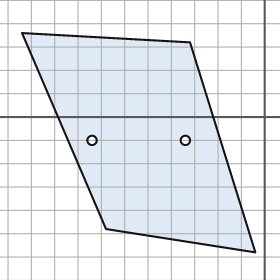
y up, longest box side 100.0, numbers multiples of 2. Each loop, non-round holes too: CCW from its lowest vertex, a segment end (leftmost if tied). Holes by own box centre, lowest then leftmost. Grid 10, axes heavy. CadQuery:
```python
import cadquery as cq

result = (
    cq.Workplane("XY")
    .moveTo(-4.0, -58.0)
    .lineTo(-32.0, 32.0)
    .lineTo(-104.0, 36.0)
    .lineTo(-68.0, -48.0)
    .close()
    .moveTo(-74.0, -10.0)
    .circle(2.0)
    .moveTo(-34.0, -10.0)
    .circle(2.0)
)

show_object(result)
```